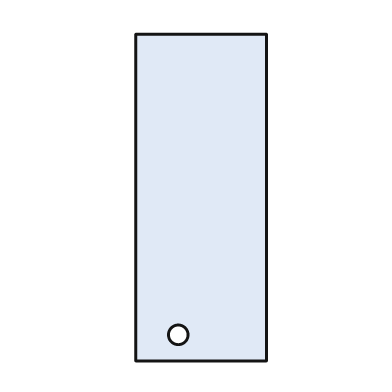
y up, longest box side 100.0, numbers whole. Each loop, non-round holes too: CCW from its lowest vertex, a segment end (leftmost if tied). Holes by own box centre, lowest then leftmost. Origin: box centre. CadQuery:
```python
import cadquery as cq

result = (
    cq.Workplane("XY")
    .moveTo(-20.0, -50.0)
    .lineTo(20.0, -50.0)
    .lineTo(20.0, 50.0)
    .lineTo(-20.0, 50.0)
    .close()
    .moveTo(-7.0, -42.0)
    .circle(3.0)
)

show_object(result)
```